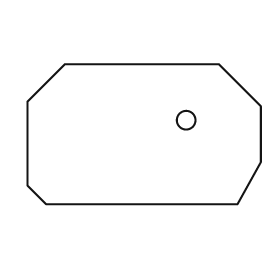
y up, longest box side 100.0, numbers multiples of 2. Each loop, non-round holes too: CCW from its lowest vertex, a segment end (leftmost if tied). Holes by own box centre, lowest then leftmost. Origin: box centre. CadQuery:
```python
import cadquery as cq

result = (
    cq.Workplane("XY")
    .moveTo(-42.0, -30.0)
    .lineTo(40.0, -30.0)
    .lineTo(50.0, -12.0)
    .lineTo(50.0, 12.0)
    .lineTo(32.0, 30.0)
    .lineTo(-34.0, 30.0)
    .lineTo(-50.0, 14.0)
    .lineTo(-50.0, -22.0)
    .close()
    .moveTo(18.0, 6.0)
    .circle(4.0)
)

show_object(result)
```